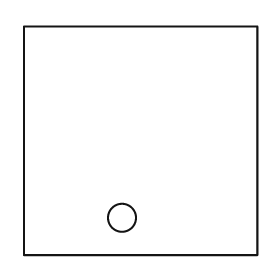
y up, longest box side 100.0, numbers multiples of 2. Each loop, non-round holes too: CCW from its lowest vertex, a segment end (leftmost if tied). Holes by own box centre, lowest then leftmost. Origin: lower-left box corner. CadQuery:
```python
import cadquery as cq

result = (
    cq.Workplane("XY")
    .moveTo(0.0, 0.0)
    .lineTo(100.0, 0.0)
    .lineTo(100.0, 98.0)
    .lineTo(0.0, 98.0)
    .close()
    .moveTo(42.0, 16.0)
    .circle(6.0)
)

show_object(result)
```